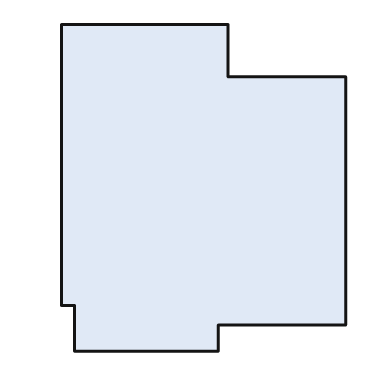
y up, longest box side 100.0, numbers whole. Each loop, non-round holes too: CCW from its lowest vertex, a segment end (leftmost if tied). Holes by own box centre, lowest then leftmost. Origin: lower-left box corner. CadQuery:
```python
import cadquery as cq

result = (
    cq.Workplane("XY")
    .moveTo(4.0, 0.0)
    .lineTo(48.0, 0.0)
    .lineTo(48.0, 8.0)
    .lineTo(87.0, 8.0)
    .lineTo(87.0, 84.0)
    .lineTo(51.0, 84.0)
    .lineTo(51.0, 100.0)
    .lineTo(0.0, 100.0)
    .lineTo(0.0, 14.0)
    .lineTo(4.0, 14.0)
    .close()
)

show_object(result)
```